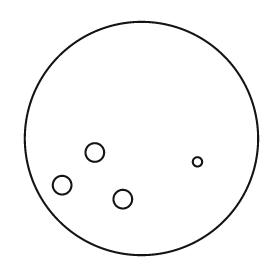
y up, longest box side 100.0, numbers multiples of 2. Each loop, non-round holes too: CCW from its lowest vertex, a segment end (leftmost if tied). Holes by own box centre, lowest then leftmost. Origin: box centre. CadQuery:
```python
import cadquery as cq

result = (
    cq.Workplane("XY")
    .moveTo(0.0, 0.0)
    .circle(50.0)
    .moveTo(-8.0, -26.0)
    .circle(4.0)
    .moveTo(-34.0, -20.0)
    .circle(4.0)
    .moveTo(24.0, -10.0)
    .circle(2.0)
    .moveTo(-20.0, -6.0)
    .circle(4.0)
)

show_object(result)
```